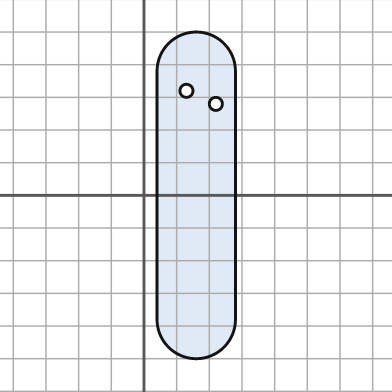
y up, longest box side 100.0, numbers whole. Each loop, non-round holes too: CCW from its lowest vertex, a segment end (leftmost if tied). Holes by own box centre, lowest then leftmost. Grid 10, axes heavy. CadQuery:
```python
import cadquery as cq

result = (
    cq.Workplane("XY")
    .moveTo(4.0, -38.0)
    .threePointArc((16.0, -50.0), (28.0, -38.0))
    .lineTo(28.0, 38.0)
    .threePointArc((16.0, 50.0), (4.0, 38.0))
    .close()
    .moveTo(22.0, 28.0)
    .circle(2.0)
    .moveTo(13.0, 32.0)
    .circle(2.0)
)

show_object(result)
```